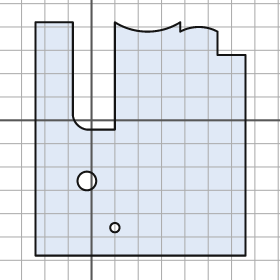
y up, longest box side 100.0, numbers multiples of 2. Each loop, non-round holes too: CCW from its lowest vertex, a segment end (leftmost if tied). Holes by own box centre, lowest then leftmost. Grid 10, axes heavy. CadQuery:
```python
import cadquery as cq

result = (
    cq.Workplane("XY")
    .moveTo(-24.0, -58.0)
    .lineTo(66.0, -58.0)
    .lineTo(66.0, 28.0)
    .lineTo(54.0, 28.0)
    .lineTo(54.0, 38.0)
    .threePointArc((46.0, 40.0), (38.0, 38.0))
    .lineTo(38.0, 42.0)
    .threePointArc((24.0, 38.0), (10.0, 42.0))
    .lineTo(10.0, -4.0)
    .lineTo(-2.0, -4.0)
    .threePointArc((-6.0, -2.0), (-8.0, 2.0))
    .lineTo(-8.0, 42.0)
    .lineTo(-24.0, 42.0)
    .close()
    .moveTo(10.0, -46.0)
    .circle(2.0)
    .moveTo(-2.0, -26.0)
    .circle(4.0)
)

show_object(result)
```